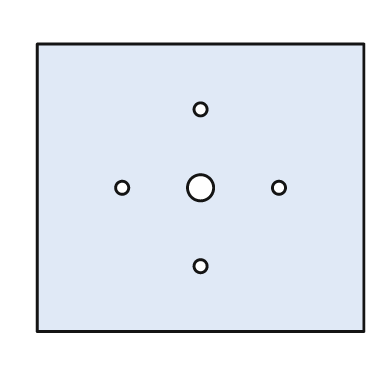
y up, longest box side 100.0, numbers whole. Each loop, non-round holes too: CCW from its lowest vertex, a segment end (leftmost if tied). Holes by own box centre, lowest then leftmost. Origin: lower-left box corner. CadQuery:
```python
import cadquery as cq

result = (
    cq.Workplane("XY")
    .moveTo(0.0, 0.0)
    .lineTo(100.0, 0.0)
    .lineTo(100.0, 88.0)
    .lineTo(0.0, 88.0)
    .close()
    .moveTo(50.0, 20.0)
    .circle(2.0)
    .moveTo(26.0, 44.0)
    .circle(2.0)
    .moveTo(50.0, 44.0)
    .circle(4.0)
    .moveTo(74.0, 44.0)
    .circle(2.0)
    .moveTo(50.0, 68.0)
    .circle(2.0)
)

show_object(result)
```